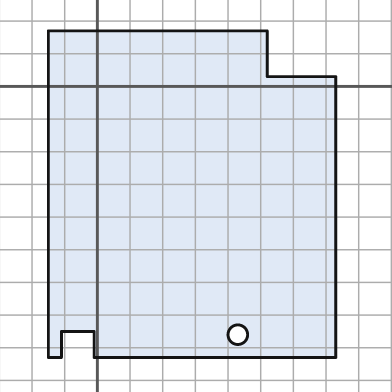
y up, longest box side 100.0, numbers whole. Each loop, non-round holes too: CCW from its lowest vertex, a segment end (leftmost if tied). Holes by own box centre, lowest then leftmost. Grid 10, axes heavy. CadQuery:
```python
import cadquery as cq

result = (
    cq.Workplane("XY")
    .moveTo(-15.0, -83.0)
    .lineTo(-11.0, -83.0)
    .lineTo(-11.0, -75.0)
    .lineTo(-1.0, -75.0)
    .lineTo(-1.0, -83.0)
    .lineTo(73.0, -83.0)
    .lineTo(73.0, 3.0)
    .lineTo(52.0, 3.0)
    .lineTo(52.0, 17.0)
    .lineTo(-15.0, 17.0)
    .close()
    .moveTo(43.0, -76.0)
    .circle(3.0)
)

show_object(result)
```